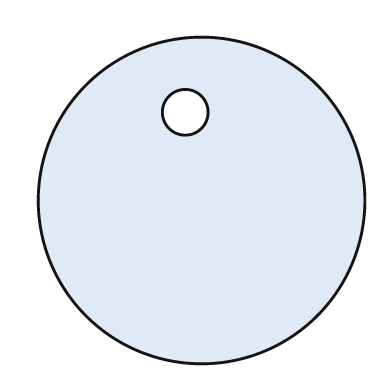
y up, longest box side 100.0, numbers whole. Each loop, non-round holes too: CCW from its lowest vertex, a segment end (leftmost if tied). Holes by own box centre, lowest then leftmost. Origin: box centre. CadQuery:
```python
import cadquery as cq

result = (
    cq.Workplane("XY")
    .moveTo(0.0, 0.0)
    .circle(50.0)
    .moveTo(-5.0, 27.0)
    .circle(7.0)
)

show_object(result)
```